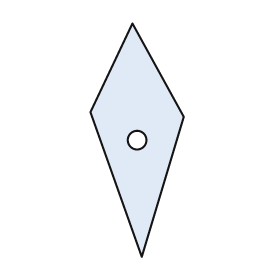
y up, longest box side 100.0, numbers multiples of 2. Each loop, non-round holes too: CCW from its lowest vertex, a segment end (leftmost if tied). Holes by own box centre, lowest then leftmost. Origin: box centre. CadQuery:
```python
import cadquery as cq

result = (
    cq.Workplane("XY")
    .moveTo(2.0, -50.0)
    .lineTo(20.0, 10.0)
    .lineTo(-2.0, 50.0)
    .lineTo(-20.0, 12.0)
    .close()
    .moveTo(0.0, 0.0)
    .circle(4.0)
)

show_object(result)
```